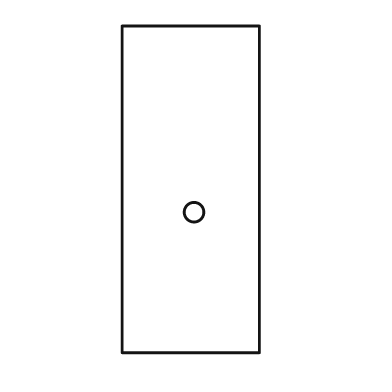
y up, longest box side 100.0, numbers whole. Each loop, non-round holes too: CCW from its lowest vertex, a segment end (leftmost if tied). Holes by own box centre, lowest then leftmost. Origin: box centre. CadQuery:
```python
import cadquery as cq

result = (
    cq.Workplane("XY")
    .moveTo(-21.0, -50.0)
    .lineTo(21.0, -50.0)
    .lineTo(21.0, 50.0)
    .lineTo(-21.0, 50.0)
    .close()
    .moveTo(1.0, -7.0)
    .circle(3.0)
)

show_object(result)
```